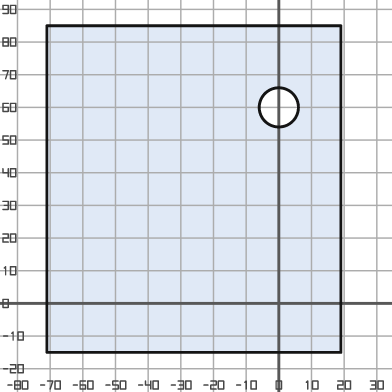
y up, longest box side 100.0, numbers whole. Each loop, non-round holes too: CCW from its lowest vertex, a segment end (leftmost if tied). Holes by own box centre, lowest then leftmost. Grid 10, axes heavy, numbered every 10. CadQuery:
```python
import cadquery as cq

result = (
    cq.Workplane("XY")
    .moveTo(-71.0, -15.0)
    .lineTo(19.0, -15.0)
    .lineTo(19.0, 85.0)
    .lineTo(-71.0, 85.0)
    .close()
    .moveTo(0.0, 60.0)
    .circle(6.0)
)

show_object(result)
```